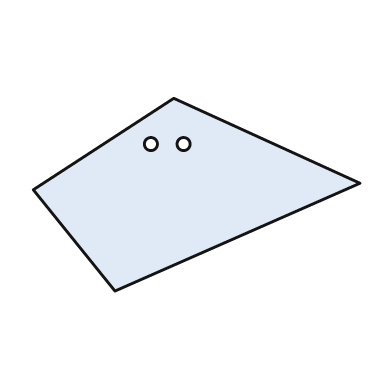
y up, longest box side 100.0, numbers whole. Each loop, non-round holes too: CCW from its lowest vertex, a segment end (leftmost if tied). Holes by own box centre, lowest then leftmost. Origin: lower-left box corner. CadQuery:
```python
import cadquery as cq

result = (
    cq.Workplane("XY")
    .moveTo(25.0, 0.0)
    .lineTo(100.0, 33.0)
    .lineTo(43.0, 59.0)
    .lineTo(0.0, 31.0)
    .close()
    .moveTo(36.0, 45.0)
    .circle(2.0)
    .moveTo(46.0, 45.0)
    .circle(2.0)
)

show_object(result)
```